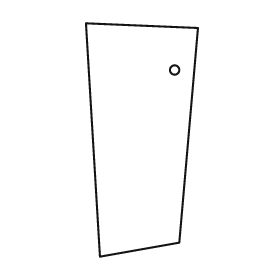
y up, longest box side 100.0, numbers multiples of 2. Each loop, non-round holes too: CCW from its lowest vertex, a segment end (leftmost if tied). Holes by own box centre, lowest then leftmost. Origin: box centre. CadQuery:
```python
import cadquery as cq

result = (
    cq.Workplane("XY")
    .moveTo(-18.0, -50.0)
    .lineTo(16.0, -44.0)
    .lineTo(24.0, 48.0)
    .lineTo(-24.0, 50.0)
    .close()
    .moveTo(14.0, 30.0)
    .circle(2.0)
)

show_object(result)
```